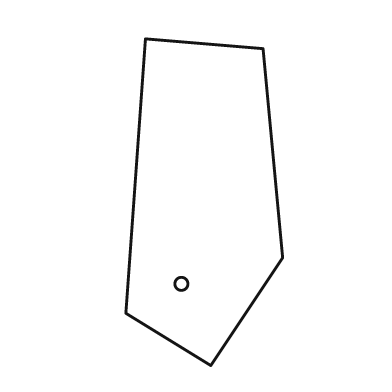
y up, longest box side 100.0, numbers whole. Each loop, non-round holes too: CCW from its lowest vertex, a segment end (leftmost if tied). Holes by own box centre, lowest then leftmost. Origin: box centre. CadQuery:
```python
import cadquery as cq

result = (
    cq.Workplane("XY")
    .moveTo(2.0, -50.0)
    .lineTo(24.0, -17.0)
    .lineTo(18.0, 47.0)
    .lineTo(-18.0, 50.0)
    .lineTo(-24.0, -34.0)
    .close()
    .moveTo(-7.0, -25.0)
    .circle(2.0)
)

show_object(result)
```